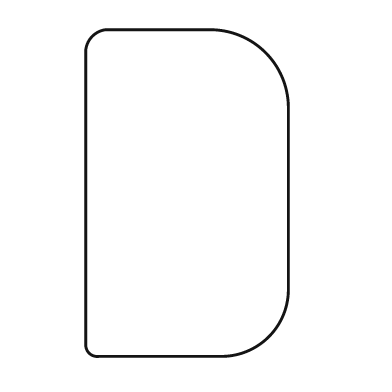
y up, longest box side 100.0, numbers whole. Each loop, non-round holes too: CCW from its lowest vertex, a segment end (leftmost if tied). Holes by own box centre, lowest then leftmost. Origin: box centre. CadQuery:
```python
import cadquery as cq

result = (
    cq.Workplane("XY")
    .moveTo(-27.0, -50.0)
    .lineTo(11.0, -50.0)
    .threePointArc((25.0, -44.0), (31.0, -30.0))
    .lineTo(31.0, 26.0)
    .threePointArc((24.0, 43.0), (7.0, 50.0))
    .lineTo(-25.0, 50.0)
    .threePointArc((-29.0, 48.0), (-31.0, 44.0))
    .lineTo(-31.0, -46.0)
    .threePointArc((-30.0, -49.0), (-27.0, -50.0))
    .close()
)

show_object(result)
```